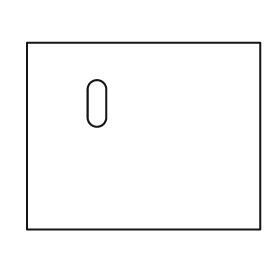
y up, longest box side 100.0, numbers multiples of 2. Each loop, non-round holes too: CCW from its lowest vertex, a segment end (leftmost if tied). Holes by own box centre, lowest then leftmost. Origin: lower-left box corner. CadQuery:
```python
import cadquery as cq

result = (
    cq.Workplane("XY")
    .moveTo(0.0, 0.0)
    .lineTo(100.0, 0.0)
    .lineTo(100.0, 80.0)
    .lineTo(0.0, 80.0)
    .close()
    .moveTo(26.0, 48.0)
    .threePointArc((30.0, 44.0), (34.0, 48.0))
    .lineTo(34.0, 60.0)
    .threePointArc((30.0, 64.0), (26.0, 60.0))
    .close()
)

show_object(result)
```